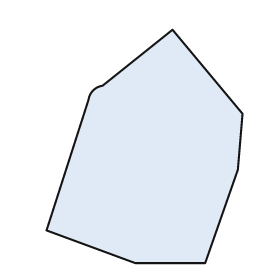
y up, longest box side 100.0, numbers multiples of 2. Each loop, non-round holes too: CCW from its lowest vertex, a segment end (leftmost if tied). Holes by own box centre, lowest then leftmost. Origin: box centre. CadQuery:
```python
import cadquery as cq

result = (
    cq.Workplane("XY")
    .moveTo(-4.0, -50.0)
    .lineTo(26.0, -50.0)
    .lineTo(40.0, -10.0)
    .lineTo(42.0, 14.0)
    .lineTo(12.0, 50.0)
    .lineTo(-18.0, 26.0)
    .threePointArc((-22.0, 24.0), (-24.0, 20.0))
    .lineTo(-42.0, -36.0)
    .close()
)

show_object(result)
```